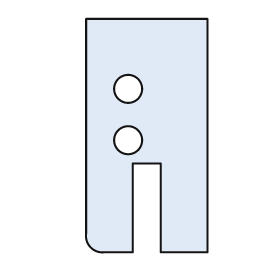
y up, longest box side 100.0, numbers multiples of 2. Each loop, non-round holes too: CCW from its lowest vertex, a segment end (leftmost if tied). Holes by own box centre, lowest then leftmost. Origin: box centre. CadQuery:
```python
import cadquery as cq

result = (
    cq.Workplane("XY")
    .moveTo(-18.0, -50.0)
    .lineTo(-6.0, -50.0)
    .lineTo(-6.0, -12.0)
    .lineTo(6.0, -12.0)
    .lineTo(6.0, -50.0)
    .lineTo(26.0, -50.0)
    .lineTo(26.0, 50.0)
    .lineTo(-26.0, 50.0)
    .lineTo(-26.0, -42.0)
    .threePointArc((-24.0, -48.0), (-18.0, -50.0))
    .close()
    .moveTo(-8.0, -2.0)
    .circle(6.0)
    .moveTo(-8.0, 20.0)
    .circle(6.0)
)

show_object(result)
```